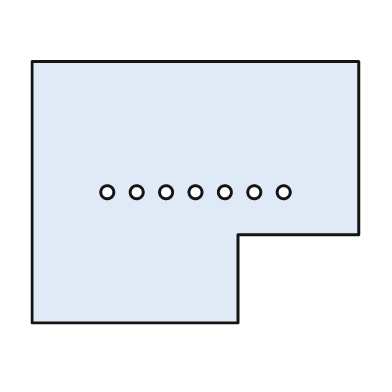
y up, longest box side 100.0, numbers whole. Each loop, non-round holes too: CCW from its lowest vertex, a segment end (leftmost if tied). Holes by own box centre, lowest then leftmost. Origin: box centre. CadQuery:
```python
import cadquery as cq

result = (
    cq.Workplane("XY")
    .moveTo(-50.0, -40.0)
    .lineTo(13.0, -40.0)
    .lineTo(13.0, -13.0)
    .lineTo(50.0, -13.0)
    .lineTo(50.0, 40.0)
    .lineTo(-50.0, 40.0)
    .close()
    .moveTo(-27.0, 0.0)
    .circle(2.0)
    .moveTo(-18.0, 0.0)
    .circle(2.0)
    .moveTo(-9.0, 0.0)
    .circle(2.0)
    .moveTo(0.0, 0.0)
    .circle(2.0)
    .moveTo(9.0, 0.0)
    .circle(2.0)
    .moveTo(18.0, 0.0)
    .circle(2.0)
    .moveTo(27.0, 0.0)
    .circle(2.0)
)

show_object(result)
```